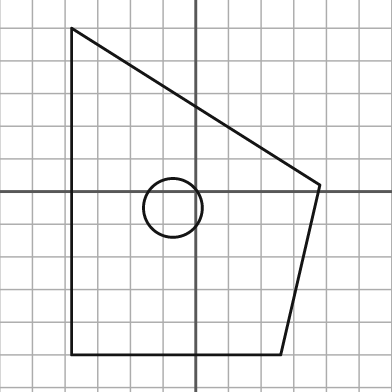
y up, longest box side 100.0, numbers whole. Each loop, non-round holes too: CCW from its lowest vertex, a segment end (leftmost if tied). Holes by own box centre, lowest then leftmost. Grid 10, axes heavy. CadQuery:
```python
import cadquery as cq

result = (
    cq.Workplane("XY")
    .moveTo(-38.0, -50.0)
    .lineTo(26.0, -50.0)
    .lineTo(38.0, 2.0)
    .lineTo(-38.0, 50.0)
    .close()
    .moveTo(-7.0, -5.0)
    .circle(9.0)
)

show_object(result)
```